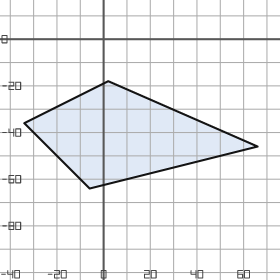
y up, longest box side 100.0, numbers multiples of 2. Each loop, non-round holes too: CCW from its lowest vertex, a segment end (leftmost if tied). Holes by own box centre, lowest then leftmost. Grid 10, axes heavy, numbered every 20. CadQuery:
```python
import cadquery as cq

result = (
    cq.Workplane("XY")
    .moveTo(-6.0, -64.0)
    .lineTo(66.0, -46.0)
    .lineTo(2.0, -18.0)
    .lineTo(-34.0, -36.0)
    .close()
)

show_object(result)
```